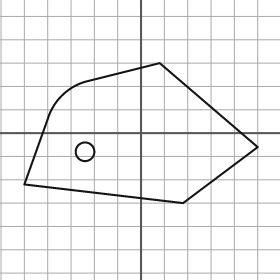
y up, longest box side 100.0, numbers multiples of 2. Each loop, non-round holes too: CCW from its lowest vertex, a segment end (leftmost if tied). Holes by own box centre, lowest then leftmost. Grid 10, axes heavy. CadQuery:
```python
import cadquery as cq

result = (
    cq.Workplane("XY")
    .moveTo(18.0, -30.0)
    .lineTo(50.0, -6.0)
    .lineTo(8.0, 30.0)
    .lineTo(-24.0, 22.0)
    .threePointArc((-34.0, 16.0), (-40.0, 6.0))
    .lineTo(-50.0, -22.0)
    .close()
    .moveTo(-24.0, -8.0)
    .circle(4.0)
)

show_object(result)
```